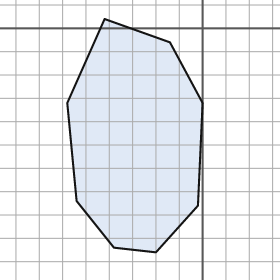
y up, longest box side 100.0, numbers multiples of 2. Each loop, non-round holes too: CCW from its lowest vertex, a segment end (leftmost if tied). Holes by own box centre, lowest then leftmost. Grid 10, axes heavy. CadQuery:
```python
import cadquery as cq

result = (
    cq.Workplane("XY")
    .moveTo(-20.0, -96.0)
    .lineTo(-2.0, -76.0)
    .lineTo(0.0, -32.0)
    .lineTo(-14.0, -6.0)
    .lineTo(-42.0, 4.0)
    .lineTo(-58.0, -32.0)
    .lineTo(-54.0, -74.0)
    .lineTo(-38.0, -94.0)
    .close()
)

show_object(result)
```